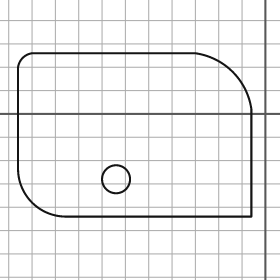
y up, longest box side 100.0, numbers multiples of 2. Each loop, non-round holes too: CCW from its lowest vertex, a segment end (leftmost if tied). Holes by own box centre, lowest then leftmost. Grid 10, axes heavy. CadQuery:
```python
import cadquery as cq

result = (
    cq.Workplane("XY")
    .moveTo(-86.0, -44.0)
    .lineTo(-6.0, -44.0)
    .lineTo(-6.0, 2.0)
    .threePointArc((-14.0, 18.0), (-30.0, 26.0))
    .lineTo(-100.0, 26.0)
    .threePointArc((-104.0, 24.0), (-106.0, 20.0))
    .lineTo(-106.0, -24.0)
    .threePointArc((-100.0, -38.0), (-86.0, -44.0))
    .close()
    .moveTo(-64.0, -28.0)
    .circle(6.0)
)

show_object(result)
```